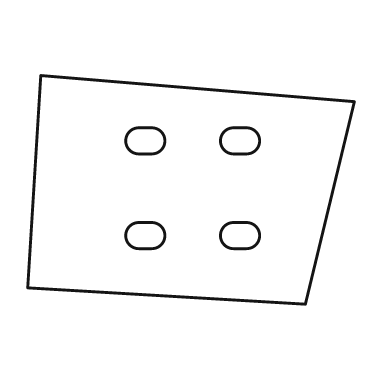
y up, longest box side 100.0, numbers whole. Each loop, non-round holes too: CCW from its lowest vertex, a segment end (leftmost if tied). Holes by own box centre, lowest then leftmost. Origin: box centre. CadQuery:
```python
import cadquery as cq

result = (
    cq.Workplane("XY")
    .moveTo(35.0, -35.0)
    .lineTo(50.0, 27.0)
    .lineTo(-46.0, 35.0)
    .lineTo(-50.0, -30.0)
    .close()
    .moveTo(-16.0, -18.0)
    .lineTo(-12.0, -18.0)
    .threePointArc((-8.0, -14.0), (-12.0, -10.0))
    .lineTo(-16.0, -10.0)
    .threePointArc((-20.0, -14.0), (-16.0, -18.0))
    .close()
    .moveTo(13.0, -18.0)
    .lineTo(17.0, -18.0)
    .threePointArc((21.0, -14.0), (17.0, -10.0))
    .lineTo(13.0, -10.0)
    .threePointArc((9.0, -14.0), (13.0, -18.0))
    .close()
    .moveTo(-16.0, 11.0)
    .lineTo(-12.0, 11.0)
    .threePointArc((-8.0, 15.0), (-12.0, 19.0))
    .lineTo(-16.0, 19.0)
    .threePointArc((-20.0, 15.0), (-16.0, 11.0))
    .close()
    .moveTo(13.0, 11.0)
    .lineTo(17.0, 11.0)
    .threePointArc((21.0, 15.0), (17.0, 19.0))
    .lineTo(13.0, 19.0)
    .threePointArc((9.0, 15.0), (13.0, 11.0))
    .close()
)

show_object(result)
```